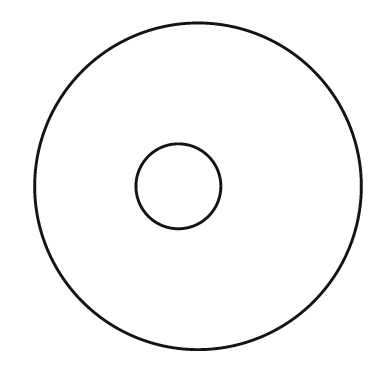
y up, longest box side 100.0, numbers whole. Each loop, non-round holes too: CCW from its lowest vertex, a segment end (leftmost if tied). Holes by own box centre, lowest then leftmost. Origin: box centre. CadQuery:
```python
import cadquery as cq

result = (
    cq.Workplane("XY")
    .moveTo(0.0, 0.0)
    .circle(50.0)
    .moveTo(-6.0, 0.0)
    .circle(13.0)
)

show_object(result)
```